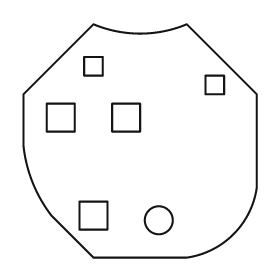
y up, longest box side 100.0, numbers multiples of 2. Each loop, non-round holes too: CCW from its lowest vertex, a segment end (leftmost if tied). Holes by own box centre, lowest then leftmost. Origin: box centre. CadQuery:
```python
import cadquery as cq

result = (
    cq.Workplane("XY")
    .moveTo(-20.0, -50.0)
    .lineTo(20.0, -50.0)
    .threePointArc((40.0, -40.0), (50.0, -20.0))
    .lineTo(50.0, 20.0)
    .lineTo(20.0, 50.0)
    .threePointArc((0.0, 46.0), (-20.0, 50.0))
    .lineTo(-50.0, 20.0)
    .lineTo(-50.0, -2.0)
    .threePointArc((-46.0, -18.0), (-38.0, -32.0))
    .close()
    .moveTo(8.0, -34.0)
    .circle(6.0)
    .moveTo(-26.0, -38.0)
    .lineTo(-14.0, -38.0)
    .lineTo(-14.0, -26.0)
    .lineTo(-26.0, -26.0)
    .close()
    .moveTo(-40.0, 4.0)
    .lineTo(-28.0, 4.0)
    .lineTo(-28.0, 16.0)
    .lineTo(-40.0, 16.0)
    .close()
    .moveTo(-12.0, 4.0)
    .lineTo(0.0, 4.0)
    .lineTo(0.0, 16.0)
    .lineTo(-12.0, 16.0)
    .close()
    .moveTo(28.0, 20.0)
    .lineTo(36.0, 20.0)
    .lineTo(36.0, 28.0)
    .lineTo(28.0, 28.0)
    .close()
    .moveTo(-24.0, 28.0)
    .lineTo(-16.0, 28.0)
    .lineTo(-16.0, 36.0)
    .lineTo(-24.0, 36.0)
    .close()
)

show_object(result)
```